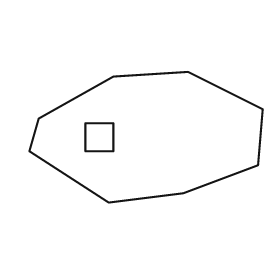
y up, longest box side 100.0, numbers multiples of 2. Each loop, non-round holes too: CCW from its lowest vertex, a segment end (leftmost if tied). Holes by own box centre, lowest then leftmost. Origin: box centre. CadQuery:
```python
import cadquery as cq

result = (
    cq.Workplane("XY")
    .moveTo(-16.0, -28.0)
    .lineTo(16.0, -24.0)
    .lineTo(48.0, -12.0)
    .lineTo(50.0, 12.0)
    .lineTo(18.0, 28.0)
    .lineTo(-14.0, 26.0)
    .lineTo(-46.0, 8.0)
    .lineTo(-50.0, -6.0)
    .close()
    .moveTo(-26.0, -6.0)
    .lineTo(-14.0, -6.0)
    .lineTo(-14.0, 6.0)
    .lineTo(-26.0, 6.0)
    .close()
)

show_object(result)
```